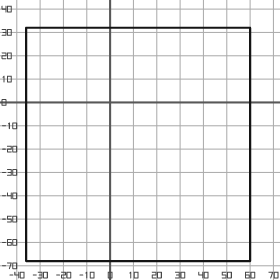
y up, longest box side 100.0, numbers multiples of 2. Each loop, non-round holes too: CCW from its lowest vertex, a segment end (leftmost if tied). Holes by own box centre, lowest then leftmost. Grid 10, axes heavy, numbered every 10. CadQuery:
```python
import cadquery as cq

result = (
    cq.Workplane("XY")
    .moveTo(-36.0, -68.0)
    .lineTo(60.0, -68.0)
    .lineTo(60.0, 32.0)
    .lineTo(-36.0, 32.0)
    .close()
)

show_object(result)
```